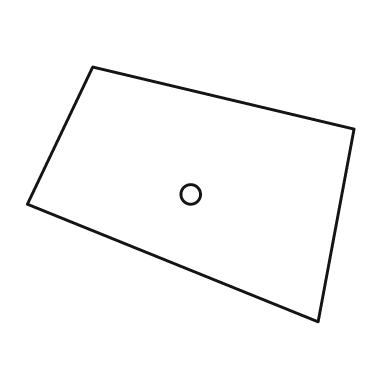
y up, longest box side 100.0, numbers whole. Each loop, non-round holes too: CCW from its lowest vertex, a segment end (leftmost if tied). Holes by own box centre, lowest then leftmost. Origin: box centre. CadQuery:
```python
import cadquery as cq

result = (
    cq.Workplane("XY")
    .moveTo(39.0, -39.0)
    .lineTo(50.0, 20.0)
    .lineTo(-30.0, 39.0)
    .lineTo(-50.0, -3.0)
    .close()
    .moveTo(0.0, 0.0)
    .circle(3.0)
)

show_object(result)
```